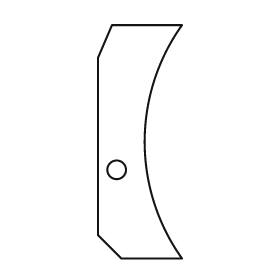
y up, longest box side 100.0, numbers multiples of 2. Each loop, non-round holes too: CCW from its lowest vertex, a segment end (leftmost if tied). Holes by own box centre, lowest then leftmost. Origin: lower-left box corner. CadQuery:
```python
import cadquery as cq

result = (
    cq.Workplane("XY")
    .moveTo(10.0, 0.0)
    .lineTo(36.0, 0.0)
    .threePointArc((20.0, 50.0), (36.0, 100.0))
    .lineTo(6.0, 100.0)
    .lineTo(0.0, 86.0)
    .lineTo(0.0, 10.0)
    .close()
    .moveTo(8.0, 38.0)
    .circle(4.0)
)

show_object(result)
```